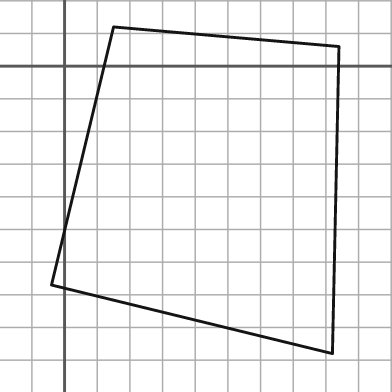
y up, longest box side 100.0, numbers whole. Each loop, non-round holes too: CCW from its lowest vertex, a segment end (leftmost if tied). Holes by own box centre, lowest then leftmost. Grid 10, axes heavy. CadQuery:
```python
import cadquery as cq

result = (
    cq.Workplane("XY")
    .moveTo(82.0, -88.0)
    .lineTo(84.0, 6.0)
    .lineTo(15.0, 12.0)
    .lineTo(-4.0, -67.0)
    .close()
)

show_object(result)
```